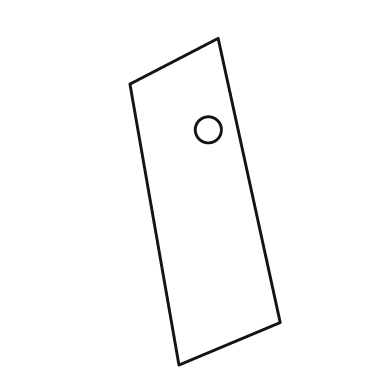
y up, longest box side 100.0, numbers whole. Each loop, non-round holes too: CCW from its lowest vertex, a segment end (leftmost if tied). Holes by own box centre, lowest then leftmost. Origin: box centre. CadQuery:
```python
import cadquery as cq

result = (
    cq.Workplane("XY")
    .moveTo(-8.0, -50.0)
    .lineTo(23.0, -37.0)
    .lineTo(4.0, 50.0)
    .lineTo(-23.0, 36.0)
    .close()
    .moveTo(1.0, 22.0)
    .circle(4.0)
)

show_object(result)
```